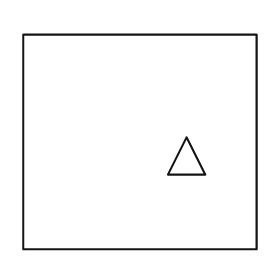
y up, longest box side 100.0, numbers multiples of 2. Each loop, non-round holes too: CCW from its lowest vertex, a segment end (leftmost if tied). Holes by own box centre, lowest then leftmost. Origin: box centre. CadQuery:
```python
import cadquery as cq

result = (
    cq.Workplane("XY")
    .moveTo(-50.0, -46.0)
    .lineTo(50.0, -46.0)
    .lineTo(50.0, 46.0)
    .lineTo(-50.0, 46.0)
    .close()
    .moveTo(12.0, -14.0)
    .lineTo(28.0, -14.0)
    .lineTo(20.0, 2.0)
    .close()
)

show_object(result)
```